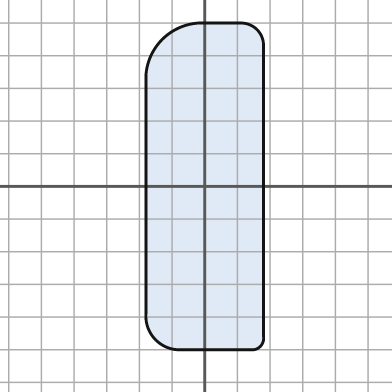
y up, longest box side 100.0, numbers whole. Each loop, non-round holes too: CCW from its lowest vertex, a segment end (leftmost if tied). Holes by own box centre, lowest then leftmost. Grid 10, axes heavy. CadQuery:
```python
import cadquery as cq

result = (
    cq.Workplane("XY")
    .moveTo(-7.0, -50.0)
    .lineTo(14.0, -50.0)
    .threePointArc((17.0, -49.0), (18.0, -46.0))
    .lineTo(18.0, 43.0)
    .threePointArc((16.0, 48.0), (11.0, 50.0))
    .lineTo(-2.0, 50.0)
    .threePointArc((-13.0, 45.0), (-18.0, 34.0))
    .lineTo(-18.0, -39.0)
    .threePointArc((-15.0, -47.0), (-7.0, -50.0))
    .close()
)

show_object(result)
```